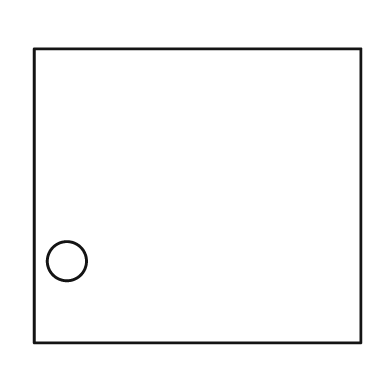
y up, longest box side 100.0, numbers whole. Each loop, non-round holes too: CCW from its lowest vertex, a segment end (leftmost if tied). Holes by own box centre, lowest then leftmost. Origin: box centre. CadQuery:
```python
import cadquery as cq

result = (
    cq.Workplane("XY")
    .moveTo(-50.0, -45.0)
    .lineTo(50.0, -45.0)
    .lineTo(50.0, 45.0)
    .lineTo(-50.0, 45.0)
    .close()
    .moveTo(-40.0, -20.0)
    .circle(6.0)
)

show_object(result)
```